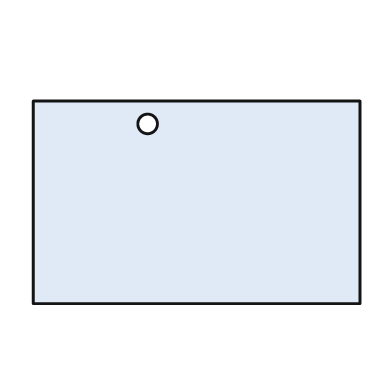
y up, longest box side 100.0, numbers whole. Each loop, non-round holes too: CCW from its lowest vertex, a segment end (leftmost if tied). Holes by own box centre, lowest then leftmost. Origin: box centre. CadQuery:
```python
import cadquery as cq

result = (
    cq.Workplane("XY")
    .moveTo(-50.0, -31.0)
    .lineTo(50.0, -31.0)
    .lineTo(50.0, 31.0)
    .lineTo(-50.0, 31.0)
    .close()
    .moveTo(-15.0, 24.0)
    .circle(3.0)
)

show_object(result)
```